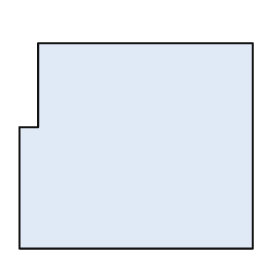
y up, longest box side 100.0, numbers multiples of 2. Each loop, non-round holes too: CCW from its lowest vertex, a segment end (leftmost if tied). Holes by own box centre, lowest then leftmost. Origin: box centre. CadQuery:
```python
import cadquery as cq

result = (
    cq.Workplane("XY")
    .moveTo(-50.0, -44.0)
    .lineTo(50.0, -44.0)
    .lineTo(50.0, 44.0)
    .lineTo(-42.0, 44.0)
    .lineTo(-42.0, 8.0)
    .lineTo(-50.0, 8.0)
    .close()
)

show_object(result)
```